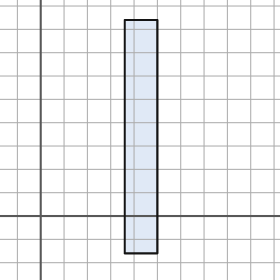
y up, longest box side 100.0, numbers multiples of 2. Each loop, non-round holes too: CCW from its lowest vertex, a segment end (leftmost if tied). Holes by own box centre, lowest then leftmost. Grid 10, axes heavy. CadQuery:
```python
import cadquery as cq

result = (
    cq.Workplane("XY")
    .moveTo(36.0, -16.0)
    .lineTo(50.0, -16.0)
    .lineTo(50.0, 84.0)
    .lineTo(36.0, 84.0)
    .close()
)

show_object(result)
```